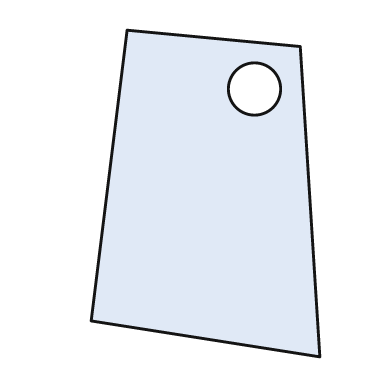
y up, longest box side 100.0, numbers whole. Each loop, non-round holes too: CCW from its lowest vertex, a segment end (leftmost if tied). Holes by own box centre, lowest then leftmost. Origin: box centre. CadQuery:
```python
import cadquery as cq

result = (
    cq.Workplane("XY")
    .moveTo(35.0, -50.0)
    .lineTo(29.0, 45.0)
    .lineTo(-24.0, 50.0)
    .lineTo(-35.0, -39.0)
    .close()
    .moveTo(15.0, 32.0)
    .circle(8.0)
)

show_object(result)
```